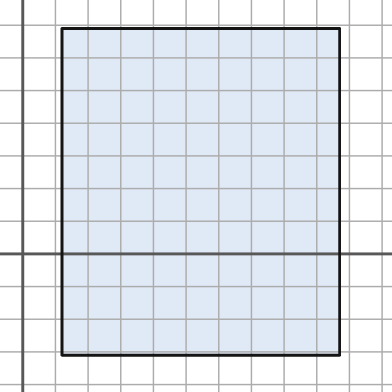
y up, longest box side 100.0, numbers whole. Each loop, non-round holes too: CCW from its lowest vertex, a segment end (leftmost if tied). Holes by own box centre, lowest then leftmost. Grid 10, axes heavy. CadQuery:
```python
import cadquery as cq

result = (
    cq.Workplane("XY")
    .moveTo(12.0, -31.0)
    .lineTo(97.0, -31.0)
    .lineTo(97.0, 69.0)
    .lineTo(12.0, 69.0)
    .close()
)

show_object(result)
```